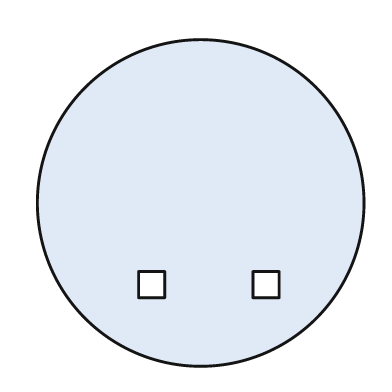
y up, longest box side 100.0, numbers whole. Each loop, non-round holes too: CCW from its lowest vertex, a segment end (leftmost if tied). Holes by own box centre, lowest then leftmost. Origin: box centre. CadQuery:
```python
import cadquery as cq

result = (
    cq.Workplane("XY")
    .moveTo(0.0, 0.0)
    .circle(50.0)
    .moveTo(-19.0, -29.0)
    .lineTo(-11.0, -29.0)
    .lineTo(-11.0, -21.0)
    .lineTo(-19.0, -21.0)
    .close()
    .moveTo(16.0, -29.0)
    .lineTo(24.0, -29.0)
    .lineTo(24.0, -21.0)
    .lineTo(16.0, -21.0)
    .close()
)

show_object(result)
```